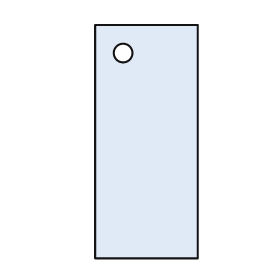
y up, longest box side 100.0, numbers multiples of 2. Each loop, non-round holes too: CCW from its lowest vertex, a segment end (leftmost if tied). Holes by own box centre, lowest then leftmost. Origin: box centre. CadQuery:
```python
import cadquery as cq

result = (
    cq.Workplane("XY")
    .moveTo(-22.0, -50.0)
    .lineTo(22.0, -50.0)
    .lineTo(22.0, 50.0)
    .lineTo(-22.0, 50.0)
    .close()
    .moveTo(-10.0, 38.0)
    .circle(4.0)
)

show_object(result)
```